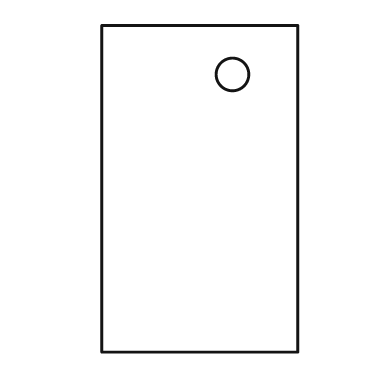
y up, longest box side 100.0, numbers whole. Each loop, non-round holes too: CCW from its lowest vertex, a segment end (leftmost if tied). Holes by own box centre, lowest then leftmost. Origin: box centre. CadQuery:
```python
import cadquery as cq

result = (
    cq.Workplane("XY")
    .moveTo(-30.0, -50.0)
    .lineTo(30.0, -50.0)
    .lineTo(30.0, 50.0)
    .lineTo(-30.0, 50.0)
    .close()
    .moveTo(10.0, 35.0)
    .circle(5.0)
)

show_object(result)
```